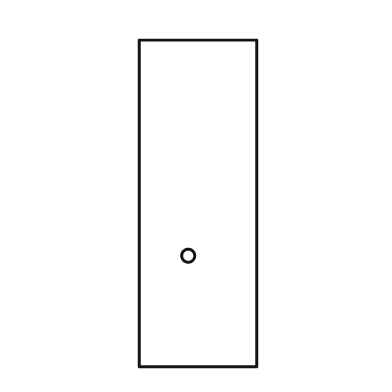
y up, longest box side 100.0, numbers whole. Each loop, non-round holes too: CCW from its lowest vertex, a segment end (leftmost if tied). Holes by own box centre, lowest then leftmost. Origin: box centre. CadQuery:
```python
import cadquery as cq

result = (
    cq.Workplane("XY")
    .moveTo(-18.0, -50.0)
    .lineTo(18.0, -50.0)
    .lineTo(18.0, 50.0)
    .lineTo(-18.0, 50.0)
    .close()
    .moveTo(-3.0, -16.0)
    .circle(2.0)
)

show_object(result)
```